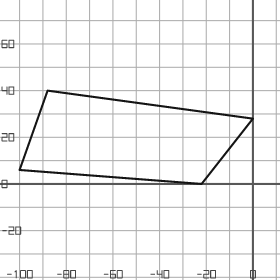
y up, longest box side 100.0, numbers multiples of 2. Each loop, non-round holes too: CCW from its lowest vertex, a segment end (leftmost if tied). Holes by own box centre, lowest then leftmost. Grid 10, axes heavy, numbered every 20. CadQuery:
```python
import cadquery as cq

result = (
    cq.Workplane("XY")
    .moveTo(-22.0, 0.0)
    .lineTo(0.0, 28.0)
    .lineTo(-88.0, 40.0)
    .lineTo(-100.0, 6.0)
    .close()
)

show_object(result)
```